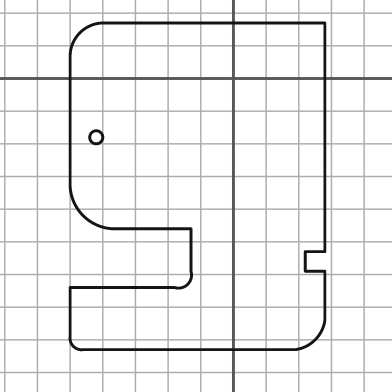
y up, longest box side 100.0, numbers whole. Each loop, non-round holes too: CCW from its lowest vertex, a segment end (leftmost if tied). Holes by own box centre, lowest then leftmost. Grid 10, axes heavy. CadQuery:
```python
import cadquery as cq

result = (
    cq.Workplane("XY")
    .moveTo(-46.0, -83.0)
    .lineTo(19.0, -83.0)
    .threePointArc((25.0, -80.0), (28.0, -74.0))
    .lineTo(28.0, -59.0)
    .lineTo(22.0, -59.0)
    .lineTo(22.0, -53.0)
    .lineTo(28.0, -53.0)
    .lineTo(28.0, 17.0)
    .lineTo(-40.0, 17.0)
    .threePointArc((-47.0, 14.0), (-50.0, 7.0))
    .lineTo(-50.0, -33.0)
    .threePointArc((-46.0, -42.0), (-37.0, -46.0))
    .lineTo(-13.0, -46.0)
    .lineTo(-13.0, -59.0)
    .threePointArc((-14.0, -63.0), (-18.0, -64.0))
    .lineTo(-50.0, -64.0)
    .lineTo(-50.0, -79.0)
    .threePointArc((-49.0, -82.0), (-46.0, -83.0))
    .close()
    .moveTo(-42.0, -18.0)
    .circle(2.0)
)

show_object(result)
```